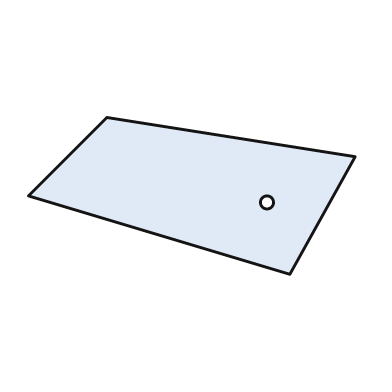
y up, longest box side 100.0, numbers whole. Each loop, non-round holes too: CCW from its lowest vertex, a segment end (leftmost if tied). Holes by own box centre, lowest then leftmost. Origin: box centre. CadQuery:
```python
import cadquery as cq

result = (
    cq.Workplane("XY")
    .moveTo(30.0, -24.0)
    .lineTo(50.0, 12.0)
    .lineTo(-26.0, 24.0)
    .lineTo(-50.0, 0.0)
    .close()
    .moveTo(23.0, -2.0)
    .circle(2.0)
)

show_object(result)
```